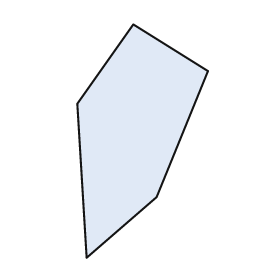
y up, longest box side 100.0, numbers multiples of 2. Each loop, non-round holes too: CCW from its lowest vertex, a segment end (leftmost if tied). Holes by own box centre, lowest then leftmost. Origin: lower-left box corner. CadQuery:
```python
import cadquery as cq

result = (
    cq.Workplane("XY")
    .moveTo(4.0, 0.0)
    .lineTo(34.0, 26.0)
    .lineTo(56.0, 80.0)
    .lineTo(24.0, 100.0)
    .lineTo(0.0, 66.0)
    .close()
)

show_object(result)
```